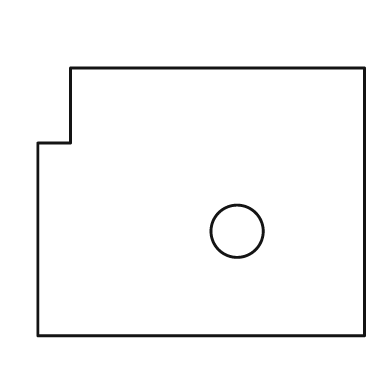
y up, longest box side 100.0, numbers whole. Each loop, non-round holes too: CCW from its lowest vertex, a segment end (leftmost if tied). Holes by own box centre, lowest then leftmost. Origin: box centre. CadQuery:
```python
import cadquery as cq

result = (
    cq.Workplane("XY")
    .moveTo(-50.0, -41.0)
    .lineTo(50.0, -41.0)
    .lineTo(50.0, 41.0)
    .lineTo(-40.0, 41.0)
    .lineTo(-40.0, 18.0)
    .lineTo(-50.0, 18.0)
    .close()
    .moveTo(11.0, -9.0)
    .circle(8.0)
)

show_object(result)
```